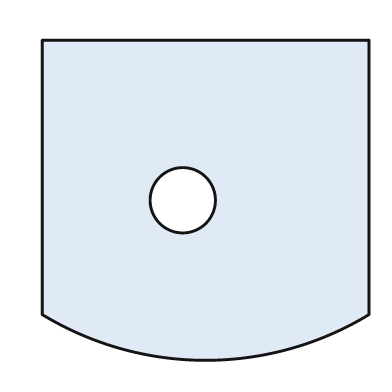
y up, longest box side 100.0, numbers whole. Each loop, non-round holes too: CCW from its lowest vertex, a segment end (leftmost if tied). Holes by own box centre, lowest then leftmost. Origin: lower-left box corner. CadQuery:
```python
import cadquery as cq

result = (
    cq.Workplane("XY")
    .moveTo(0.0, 14.0)
    .threePointArc((50.0, 0.0), (100.0, 14.0))
    .lineTo(100.0, 98.0)
    .lineTo(0.0, 98.0)
    .close()
    .moveTo(43.0, 49.0)
    .circle(10.0)
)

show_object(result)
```